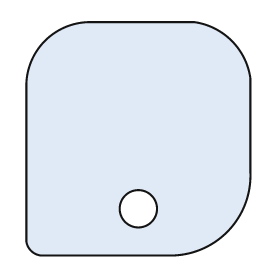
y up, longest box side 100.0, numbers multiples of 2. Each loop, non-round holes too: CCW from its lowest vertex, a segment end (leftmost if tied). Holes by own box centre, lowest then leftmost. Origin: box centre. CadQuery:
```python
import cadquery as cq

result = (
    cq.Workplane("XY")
    .moveTo(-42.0, -50.0)
    .lineTo(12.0, -50.0)
    .threePointArc((38.0, -40.0), (48.0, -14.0))
    .lineTo(48.0, 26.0)
    .threePointArc((40.0, 42.0), (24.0, 50.0))
    .lineTo(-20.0, 50.0)
    .threePointArc((-40.0, 42.0), (-48.0, 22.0))
    .lineTo(-48.0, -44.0)
    .threePointArc((-46.0, -48.0), (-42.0, -50.0))
    .close()
    .moveTo(0.0, -30.0)
    .circle(8.0)
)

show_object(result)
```